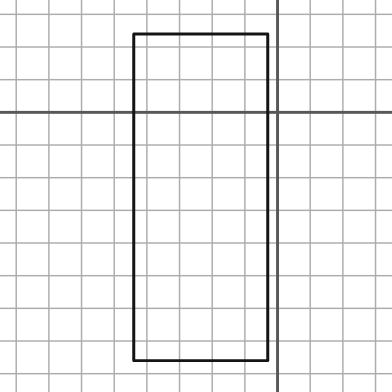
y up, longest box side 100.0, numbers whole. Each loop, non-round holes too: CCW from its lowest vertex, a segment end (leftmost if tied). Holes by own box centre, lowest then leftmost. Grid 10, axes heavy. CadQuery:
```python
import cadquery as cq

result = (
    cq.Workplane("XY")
    .moveTo(-44.0, -76.0)
    .lineTo(-3.0, -76.0)
    .lineTo(-3.0, 24.0)
    .lineTo(-44.0, 24.0)
    .close()
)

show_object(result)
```